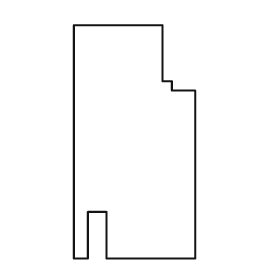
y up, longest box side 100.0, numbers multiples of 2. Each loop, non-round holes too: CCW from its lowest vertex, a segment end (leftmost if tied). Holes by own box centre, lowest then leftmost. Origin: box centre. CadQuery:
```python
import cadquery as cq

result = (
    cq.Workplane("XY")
    .moveTo(-26.0, -50.0)
    .lineTo(-20.0, -50.0)
    .lineTo(-20.0, -30.0)
    .lineTo(-12.0, -30.0)
    .lineTo(-12.0, -50.0)
    .lineTo(26.0, -50.0)
    .lineTo(26.0, 22.0)
    .lineTo(16.0, 22.0)
    .lineTo(16.0, 26.0)
    .lineTo(12.0, 26.0)
    .lineTo(12.0, 50.0)
    .lineTo(-26.0, 50.0)
    .close()
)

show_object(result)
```